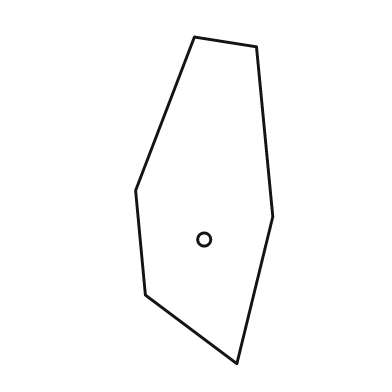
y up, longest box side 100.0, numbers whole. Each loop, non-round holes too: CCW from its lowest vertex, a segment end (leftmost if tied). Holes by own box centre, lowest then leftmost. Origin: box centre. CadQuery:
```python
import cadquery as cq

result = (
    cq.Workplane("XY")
    .moveTo(10.0, -50.0)
    .lineTo(21.0, -5.0)
    .lineTo(16.0, 47.0)
    .lineTo(-3.0, 50.0)
    .lineTo(-21.0, 3.0)
    .lineTo(-18.0, -29.0)
    .close()
    .moveTo(0.0, -12.0)
    .circle(2.0)
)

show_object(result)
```